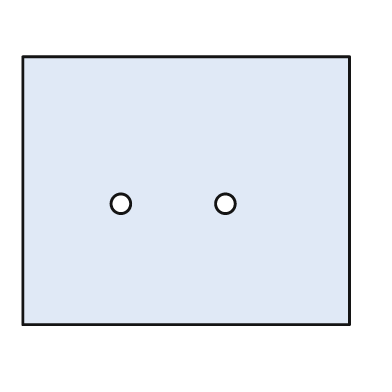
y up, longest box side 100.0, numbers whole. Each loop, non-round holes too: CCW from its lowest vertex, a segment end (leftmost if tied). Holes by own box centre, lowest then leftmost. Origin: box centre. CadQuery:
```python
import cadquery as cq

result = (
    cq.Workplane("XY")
    .moveTo(-50.0, -41.0)
    .lineTo(50.0, -41.0)
    .lineTo(50.0, 41.0)
    .lineTo(-50.0, 41.0)
    .close()
    .moveTo(-20.0, -4.0)
    .circle(3.0)
    .moveTo(12.0, -4.0)
    .circle(3.0)
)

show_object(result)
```